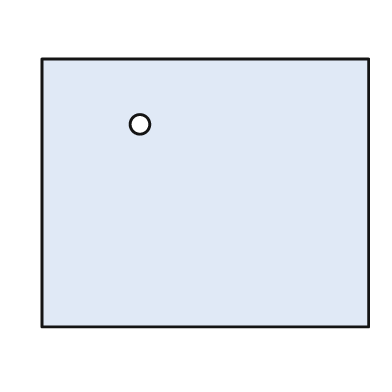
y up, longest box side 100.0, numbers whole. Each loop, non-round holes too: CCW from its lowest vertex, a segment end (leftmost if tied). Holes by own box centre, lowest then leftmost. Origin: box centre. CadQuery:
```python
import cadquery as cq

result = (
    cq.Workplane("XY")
    .moveTo(-50.0, -41.0)
    .lineTo(50.0, -41.0)
    .lineTo(50.0, 41.0)
    .lineTo(-50.0, 41.0)
    .close()
    .moveTo(-20.0, 21.0)
    .circle(3.0)
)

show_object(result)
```